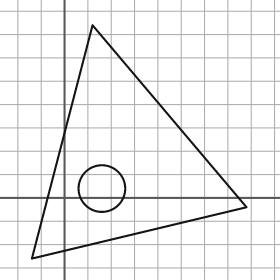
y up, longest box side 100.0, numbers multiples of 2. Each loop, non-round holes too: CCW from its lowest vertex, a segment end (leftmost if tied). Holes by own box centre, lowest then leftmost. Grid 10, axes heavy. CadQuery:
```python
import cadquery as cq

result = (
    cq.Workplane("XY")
    .moveTo(-14.0, -26.0)
    .lineTo(78.0, -4.0)
    .lineTo(12.0, 74.0)
    .close()
    .moveTo(16.0, 4.0)
    .circle(10.0)
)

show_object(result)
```